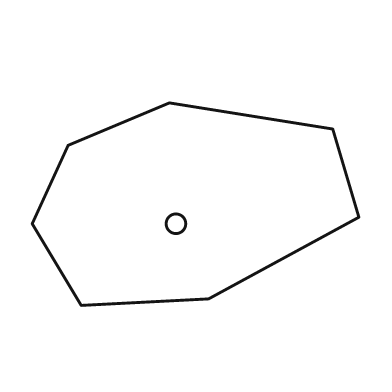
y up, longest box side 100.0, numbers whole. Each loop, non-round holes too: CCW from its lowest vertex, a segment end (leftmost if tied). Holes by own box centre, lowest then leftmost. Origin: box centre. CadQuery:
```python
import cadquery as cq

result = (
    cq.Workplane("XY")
    .moveTo(-35.0, -31.0)
    .lineTo(4.0, -29.0)
    .lineTo(50.0, -4.0)
    .lineTo(42.0, 23.0)
    .lineTo(-8.0, 31.0)
    .lineTo(-39.0, 18.0)
    .lineTo(-50.0, -6.0)
    .close()
    .moveTo(-6.0, -6.0)
    .circle(3.0)
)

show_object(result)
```